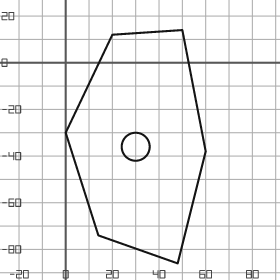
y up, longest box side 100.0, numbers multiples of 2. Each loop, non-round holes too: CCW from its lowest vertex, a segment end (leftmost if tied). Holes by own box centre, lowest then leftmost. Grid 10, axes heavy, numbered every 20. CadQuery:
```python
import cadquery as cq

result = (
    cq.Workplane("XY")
    .moveTo(48.0, -86.0)
    .lineTo(60.0, -38.0)
    .lineTo(50.0, 14.0)
    .lineTo(20.0, 12.0)
    .lineTo(0.0, -30.0)
    .lineTo(14.0, -74.0)
    .close()
    .moveTo(30.0, -36.0)
    .circle(6.0)
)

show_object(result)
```